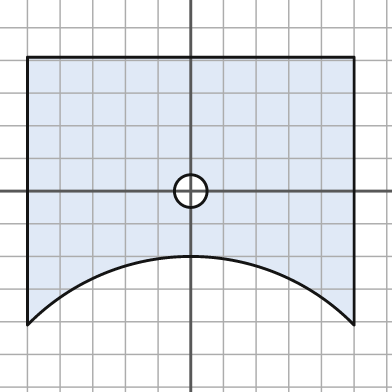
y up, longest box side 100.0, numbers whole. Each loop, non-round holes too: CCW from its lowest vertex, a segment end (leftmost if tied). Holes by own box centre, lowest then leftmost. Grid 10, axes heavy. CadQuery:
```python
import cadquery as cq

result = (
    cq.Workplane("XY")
    .moveTo(-50.0, -41.0)
    .threePointArc((0.0, -20.0), (50.0, -41.0))
    .lineTo(50.0, 41.0)
    .lineTo(-50.0, 41.0)
    .close()
    .moveTo(0.0, 0.0)
    .circle(5.0)
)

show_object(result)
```